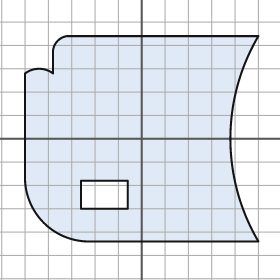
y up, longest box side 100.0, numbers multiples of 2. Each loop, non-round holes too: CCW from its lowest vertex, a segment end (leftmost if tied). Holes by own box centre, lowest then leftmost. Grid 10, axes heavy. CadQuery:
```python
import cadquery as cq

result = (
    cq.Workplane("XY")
    .moveTo(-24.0, -44.0)
    .lineTo(50.0, -44.0)
    .threePointArc((38.0, 0.0), (50.0, 44.0))
    .lineTo(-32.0, 44.0)
    .threePointArc((-36.0, 42.0), (-38.0, 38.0))
    .lineTo(-38.0, 28.0)
    .threePointArc((-44.0, 30.0), (-50.0, 28.0))
    .lineTo(-50.0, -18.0)
    .threePointArc((-42.0, -36.0), (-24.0, -44.0))
    .close()
    .moveTo(-26.0, -30.0)
    .lineTo(-6.0, -30.0)
    .lineTo(-6.0, -18.0)
    .lineTo(-26.0, -18.0)
    .close()
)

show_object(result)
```